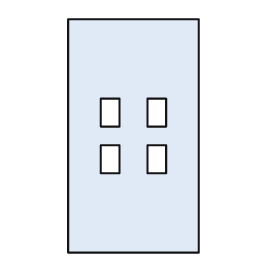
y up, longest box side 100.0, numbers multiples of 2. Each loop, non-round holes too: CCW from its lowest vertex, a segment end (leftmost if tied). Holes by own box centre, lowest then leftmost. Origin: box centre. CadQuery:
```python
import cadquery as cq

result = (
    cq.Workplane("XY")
    .moveTo(-28.0, -50.0)
    .lineTo(28.0, -50.0)
    .lineTo(28.0, 50.0)
    .lineTo(-28.0, 50.0)
    .close()
    .moveTo(-14.0, -16.0)
    .lineTo(-6.0, -16.0)
    .lineTo(-6.0, -4.0)
    .lineTo(-14.0, -4.0)
    .close()
    .moveTo(6.0, -16.0)
    .lineTo(14.0, -16.0)
    .lineTo(14.0, -4.0)
    .lineTo(6.0, -4.0)
    .close()
    .moveTo(-14.0, 4.0)
    .lineTo(-6.0, 4.0)
    .lineTo(-6.0, 16.0)
    .lineTo(-14.0, 16.0)
    .close()
    .moveTo(6.0, 4.0)
    .lineTo(14.0, 4.0)
    .lineTo(14.0, 16.0)
    .lineTo(6.0, 16.0)
    .close()
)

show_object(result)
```